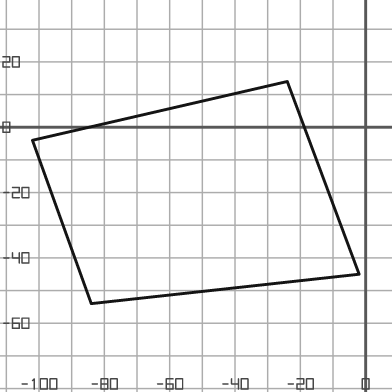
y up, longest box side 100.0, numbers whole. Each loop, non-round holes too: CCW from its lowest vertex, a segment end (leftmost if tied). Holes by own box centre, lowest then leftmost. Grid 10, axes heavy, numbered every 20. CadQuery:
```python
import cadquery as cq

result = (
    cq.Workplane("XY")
    .moveTo(-84.0, -54.0)
    .lineTo(-2.0, -45.0)
    .lineTo(-24.0, 14.0)
    .lineTo(-102.0, -4.0)
    .close()
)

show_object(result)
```